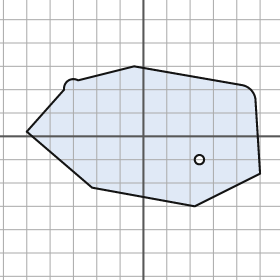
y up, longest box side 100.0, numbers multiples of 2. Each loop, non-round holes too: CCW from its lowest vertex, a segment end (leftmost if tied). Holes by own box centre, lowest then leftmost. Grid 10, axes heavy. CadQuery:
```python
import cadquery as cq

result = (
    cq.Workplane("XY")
    .moveTo(22.0, -30.0)
    .lineTo(50.0, -16.0)
    .lineTo(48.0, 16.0)
    .threePointArc((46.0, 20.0), (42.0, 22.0))
    .lineTo(-4.0, 30.0)
    .lineTo(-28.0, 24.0)
    .threePointArc((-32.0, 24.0), (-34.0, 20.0))
    .lineTo(-50.0, 2.0)
    .lineTo(-22.0, -22.0)
    .close()
    .moveTo(24.0, -10.0)
    .circle(2.0)
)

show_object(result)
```